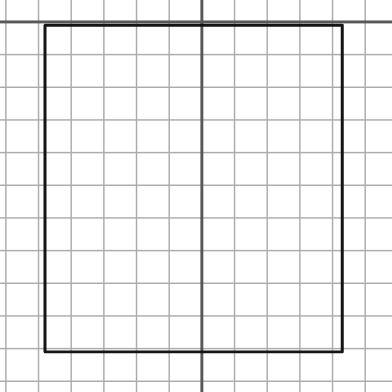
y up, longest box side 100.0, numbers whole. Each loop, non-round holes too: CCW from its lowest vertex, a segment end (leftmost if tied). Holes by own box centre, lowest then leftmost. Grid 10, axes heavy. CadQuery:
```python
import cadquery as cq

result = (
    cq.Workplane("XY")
    .moveTo(-48.0, -101.0)
    .lineTo(43.0, -101.0)
    .lineTo(43.0, -1.0)
    .lineTo(-48.0, -1.0)
    .close()
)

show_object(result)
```